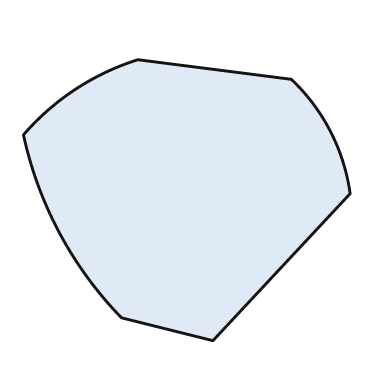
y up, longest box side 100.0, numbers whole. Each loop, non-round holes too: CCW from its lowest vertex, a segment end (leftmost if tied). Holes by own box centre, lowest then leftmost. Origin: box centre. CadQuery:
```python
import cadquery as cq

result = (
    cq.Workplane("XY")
    .moveTo(8.0, -43.0)
    .lineTo(50.0, 2.0)
    .threePointArc((44.0, 21.0), (32.0, 37.0))
    .lineTo(-15.0, 43.0)
    .threePointArc((-34.0, 34.0), (-50.0, 20.0))
    .threePointArc((-39.0, -10.0), (-20.0, -36.0))
    .close()
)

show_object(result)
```